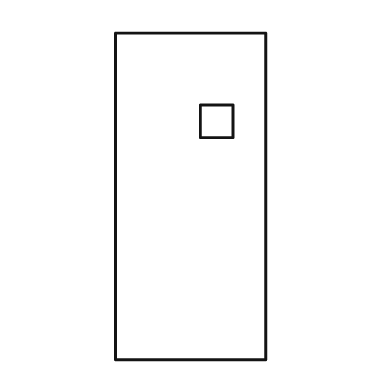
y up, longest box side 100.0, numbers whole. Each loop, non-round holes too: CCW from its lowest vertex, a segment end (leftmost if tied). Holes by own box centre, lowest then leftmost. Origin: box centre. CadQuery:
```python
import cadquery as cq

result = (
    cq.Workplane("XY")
    .moveTo(-23.0, -50.0)
    .lineTo(23.0, -50.0)
    .lineTo(23.0, 50.0)
    .lineTo(-23.0, 50.0)
    .close()
    .moveTo(3.0, 18.0)
    .lineTo(13.0, 18.0)
    .lineTo(13.0, 28.0)
    .lineTo(3.0, 28.0)
    .close()
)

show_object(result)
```